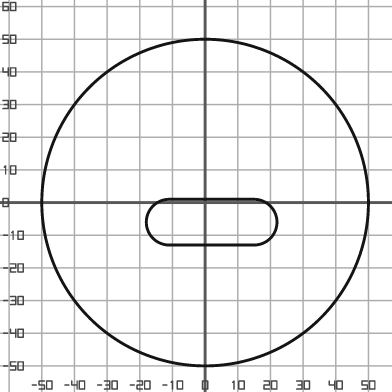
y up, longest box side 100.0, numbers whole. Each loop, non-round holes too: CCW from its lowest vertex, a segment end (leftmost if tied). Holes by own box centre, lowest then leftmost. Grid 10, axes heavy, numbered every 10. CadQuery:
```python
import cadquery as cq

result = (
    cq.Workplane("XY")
    .moveTo(0.0, 0.0)
    .circle(50.0)
    .moveTo(-11.0, -13.0)
    .lineTo(15.0, -13.0)
    .threePointArc((22.0, -6.0), (15.0, 1.0))
    .lineTo(-11.0, 1.0)
    .threePointArc((-18.0, -6.0), (-11.0, -13.0))
    .close()
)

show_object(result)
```